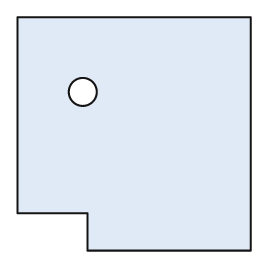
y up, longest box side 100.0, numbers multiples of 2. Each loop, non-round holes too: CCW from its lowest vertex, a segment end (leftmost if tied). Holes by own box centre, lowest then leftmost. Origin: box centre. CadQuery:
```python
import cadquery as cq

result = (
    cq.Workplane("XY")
    .moveTo(-20.0, -50.0)
    .lineTo(50.0, -50.0)
    .lineTo(50.0, 50.0)
    .lineTo(-50.0, 50.0)
    .lineTo(-50.0, -34.0)
    .lineTo(-20.0, -34.0)
    .close()
    .moveTo(-22.0, 18.0)
    .circle(6.0)
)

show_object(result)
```